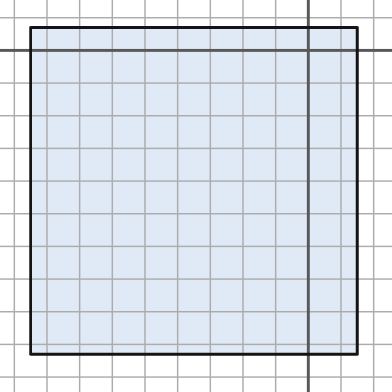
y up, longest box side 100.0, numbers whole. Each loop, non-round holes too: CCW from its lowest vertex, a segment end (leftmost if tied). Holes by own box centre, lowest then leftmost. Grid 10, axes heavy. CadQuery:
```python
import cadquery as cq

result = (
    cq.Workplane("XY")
    .moveTo(-85.0, -93.0)
    .lineTo(15.0, -93.0)
    .lineTo(15.0, 7.0)
    .lineTo(-85.0, 7.0)
    .close()
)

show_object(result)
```